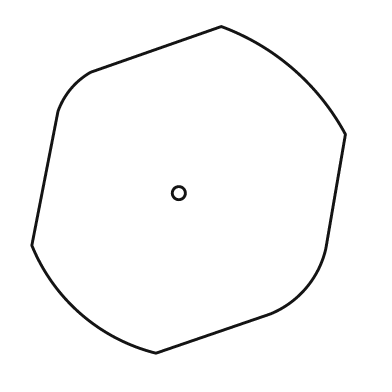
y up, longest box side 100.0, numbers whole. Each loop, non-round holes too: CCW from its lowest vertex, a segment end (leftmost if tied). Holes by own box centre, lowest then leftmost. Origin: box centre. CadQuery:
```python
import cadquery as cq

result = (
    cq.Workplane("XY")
    .moveTo(-10.0, -50.0)
    .lineTo(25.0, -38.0)
    .threePointArc((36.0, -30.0), (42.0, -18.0))
    .lineTo(48.0, 17.0)
    .threePointArc((32.0, 37.0), (10.0, 50.0))
    .lineTo(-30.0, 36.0)
    .threePointArc((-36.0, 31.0), (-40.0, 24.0))
    .lineTo(-48.0, -17.0)
    .threePointArc((-33.0, -38.0), (-10.0, -50.0))
    .close()
    .moveTo(-3.0, -1.0)
    .circle(2.0)
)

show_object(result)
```